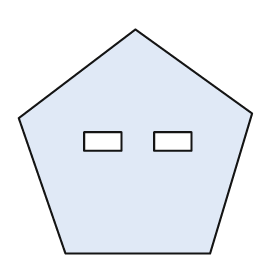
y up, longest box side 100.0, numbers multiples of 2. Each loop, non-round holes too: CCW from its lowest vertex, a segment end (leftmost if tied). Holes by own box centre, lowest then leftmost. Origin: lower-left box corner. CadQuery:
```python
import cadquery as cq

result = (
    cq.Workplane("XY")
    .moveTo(20.0, 0.0)
    .lineTo(82.0, 0.0)
    .lineTo(100.0, 60.0)
    .lineTo(50.0, 96.0)
    .lineTo(0.0, 58.0)
    .close()
    .moveTo(28.0, 44.0)
    .lineTo(44.0, 44.0)
    .lineTo(44.0, 52.0)
    .lineTo(28.0, 52.0)
    .close()
    .moveTo(58.0, 44.0)
    .lineTo(74.0, 44.0)
    .lineTo(74.0, 52.0)
    .lineTo(58.0, 52.0)
    .close()
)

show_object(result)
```